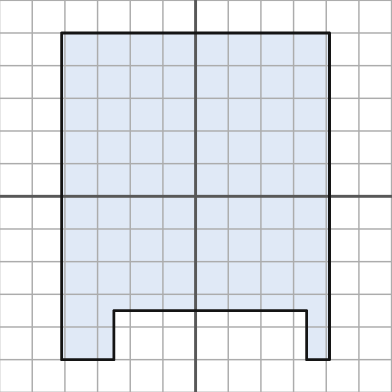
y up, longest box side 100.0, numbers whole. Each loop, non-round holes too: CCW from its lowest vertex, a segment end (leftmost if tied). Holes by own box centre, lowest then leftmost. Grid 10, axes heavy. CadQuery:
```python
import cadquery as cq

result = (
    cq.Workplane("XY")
    .moveTo(-41.0, -50.0)
    .lineTo(-25.0, -50.0)
    .lineTo(-25.0, -35.0)
    .lineTo(34.0, -35.0)
    .lineTo(34.0, -50.0)
    .lineTo(41.0, -50.0)
    .lineTo(41.0, 50.0)
    .lineTo(-41.0, 50.0)
    .close()
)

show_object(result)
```